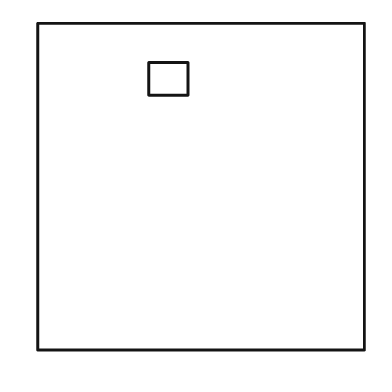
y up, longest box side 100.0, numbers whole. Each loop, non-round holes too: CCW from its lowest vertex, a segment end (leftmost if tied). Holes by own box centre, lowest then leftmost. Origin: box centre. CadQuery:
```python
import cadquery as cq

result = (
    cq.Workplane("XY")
    .moveTo(-50.0, -50.0)
    .lineTo(50.0, -50.0)
    .lineTo(50.0, 50.0)
    .lineTo(-50.0, 50.0)
    .close()
    .moveTo(-16.0, 28.0)
    .lineTo(-4.0, 28.0)
    .lineTo(-4.0, 38.0)
    .lineTo(-16.0, 38.0)
    .close()
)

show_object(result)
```